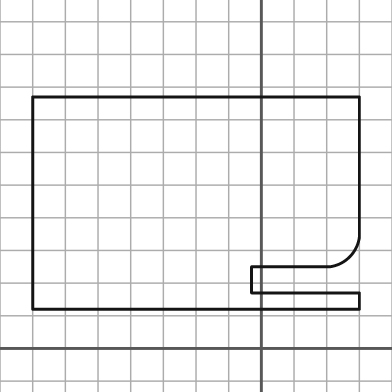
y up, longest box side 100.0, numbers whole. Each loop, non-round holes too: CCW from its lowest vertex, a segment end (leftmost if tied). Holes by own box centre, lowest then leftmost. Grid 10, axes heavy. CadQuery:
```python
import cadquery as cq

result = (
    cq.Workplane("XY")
    .moveTo(-70.0, 12.0)
    .lineTo(30.0, 12.0)
    .lineTo(30.0, 17.0)
    .lineTo(-3.0, 17.0)
    .lineTo(-3.0, 25.0)
    .lineTo(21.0, 25.0)
    .threePointArc((27.0, 28.0), (30.0, 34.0))
    .lineTo(30.0, 77.0)
    .lineTo(-70.0, 77.0)
    .close()
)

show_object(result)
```